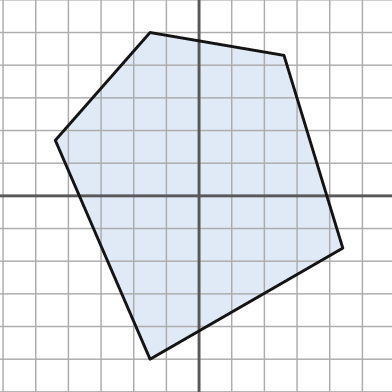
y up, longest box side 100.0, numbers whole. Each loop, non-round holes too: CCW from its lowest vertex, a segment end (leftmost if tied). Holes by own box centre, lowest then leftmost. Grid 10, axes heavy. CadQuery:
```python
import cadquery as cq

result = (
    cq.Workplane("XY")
    .moveTo(-15.0, -50.0)
    .lineTo(44.0, -16.0)
    .lineTo(26.0, 43.0)
    .lineTo(-15.0, 50.0)
    .lineTo(-44.0, 17.0)
    .close()
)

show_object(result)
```